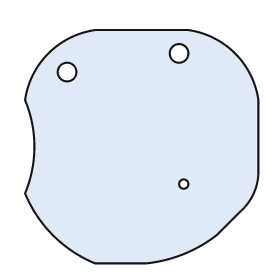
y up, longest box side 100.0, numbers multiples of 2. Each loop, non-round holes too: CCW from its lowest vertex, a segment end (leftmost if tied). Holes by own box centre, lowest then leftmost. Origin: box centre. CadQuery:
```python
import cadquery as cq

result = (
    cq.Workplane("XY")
    .moveTo(-20.0, -50.0)
    .lineTo(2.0, -50.0)
    .threePointArc((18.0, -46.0), (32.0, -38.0))
    .lineTo(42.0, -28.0)
    .threePointArc((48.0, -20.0), (50.0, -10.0))
    .lineTo(50.0, 20.0)
    .threePointArc((40.0, 40.0), (20.0, 50.0))
    .lineTo(-20.0, 50.0)
    .threePointArc((-40.0, 40.0), (-50.0, 20.0))
    .threePointArc((-46.0, 0.0), (-50.0, -20.0))
    .threePointArc((-38.0, -38.0), (-20.0, -50.0))
    .close()
    .moveTo(18.0, -16.0)
    .circle(2.0)
    .moveTo(-32.0, 32.0)
    .circle(4.0)
    .moveTo(16.0, 40.0)
    .circle(4.0)
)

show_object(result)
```